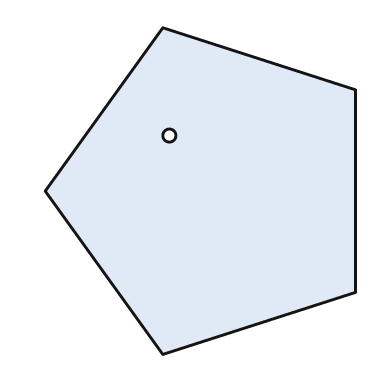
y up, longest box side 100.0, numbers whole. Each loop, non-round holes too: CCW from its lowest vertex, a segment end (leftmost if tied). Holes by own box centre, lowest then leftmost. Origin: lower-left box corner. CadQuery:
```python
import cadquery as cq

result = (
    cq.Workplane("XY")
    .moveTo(36.0, 0.0)
    .lineTo(95.0, 19.0)
    .lineTo(95.0, 81.0)
    .lineTo(36.0, 100.0)
    .lineTo(0.0, 50.0)
    .close()
    .moveTo(38.0, 67.0)
    .circle(2.0)
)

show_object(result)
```